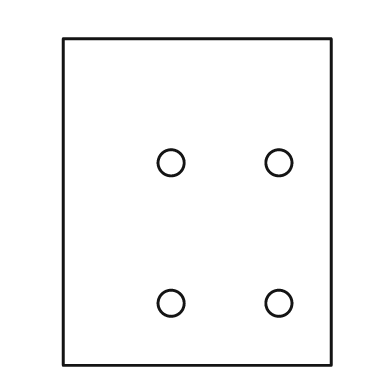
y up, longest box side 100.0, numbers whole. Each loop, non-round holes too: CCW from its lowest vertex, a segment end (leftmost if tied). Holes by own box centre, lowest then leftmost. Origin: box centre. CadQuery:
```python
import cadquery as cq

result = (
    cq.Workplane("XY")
    .moveTo(-41.0, -50.0)
    .lineTo(41.0, -50.0)
    .lineTo(41.0, 50.0)
    .lineTo(-41.0, 50.0)
    .close()
    .moveTo(-8.0, -31.0)
    .circle(4.0)
    .moveTo(25.0, -31.0)
    .circle(4.0)
    .moveTo(-8.0, 12.0)
    .circle(4.0)
    .moveTo(25.0, 12.0)
    .circle(4.0)
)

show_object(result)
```